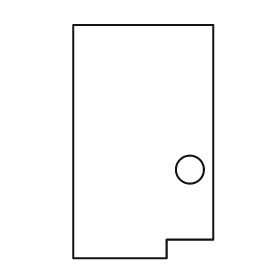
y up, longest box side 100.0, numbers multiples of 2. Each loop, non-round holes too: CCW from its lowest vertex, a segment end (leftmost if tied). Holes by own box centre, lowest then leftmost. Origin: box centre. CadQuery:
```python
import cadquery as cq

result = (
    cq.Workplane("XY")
    .moveTo(-30.0, -50.0)
    .lineTo(10.0, -50.0)
    .lineTo(10.0, -42.0)
    .lineTo(30.0, -42.0)
    .lineTo(30.0, 50.0)
    .lineTo(-30.0, 50.0)
    .close()
    .moveTo(20.0, -12.0)
    .circle(6.0)
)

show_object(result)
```